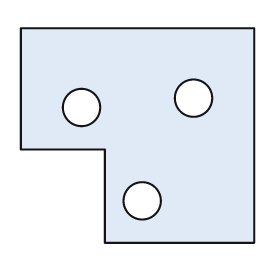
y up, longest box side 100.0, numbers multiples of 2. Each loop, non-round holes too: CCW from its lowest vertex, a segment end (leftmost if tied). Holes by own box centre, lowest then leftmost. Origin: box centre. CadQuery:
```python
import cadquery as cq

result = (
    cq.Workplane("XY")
    .moveTo(-14.0, -46.0)
    .lineTo(50.0, -46.0)
    .lineTo(50.0, 46.0)
    .lineTo(-50.0, 46.0)
    .lineTo(-50.0, -6.0)
    .lineTo(-14.0, -6.0)
    .close()
    .moveTo(2.0, -28.0)
    .circle(8.0)
    .moveTo(-24.0, 12.0)
    .circle(8.0)
    .moveTo(24.0, 16.0)
    .circle(8.0)
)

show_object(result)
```